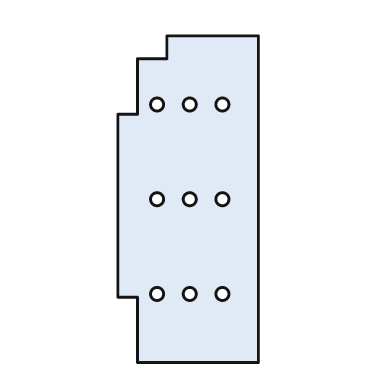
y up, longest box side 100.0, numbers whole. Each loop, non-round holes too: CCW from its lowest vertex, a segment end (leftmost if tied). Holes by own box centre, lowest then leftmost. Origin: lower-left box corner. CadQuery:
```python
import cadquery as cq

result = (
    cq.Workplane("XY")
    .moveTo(6.0, 0.0)
    .lineTo(43.0, 0.0)
    .lineTo(43.0, 100.0)
    .lineTo(15.0, 100.0)
    .lineTo(15.0, 93.0)
    .lineTo(6.0, 93.0)
    .lineTo(6.0, 76.0)
    .lineTo(0.0, 76.0)
    .lineTo(0.0, 20.0)
    .lineTo(6.0, 20.0)
    .close()
    .moveTo(12.0, 21.0)
    .circle(2.0)
    .moveTo(22.0, 21.0)
    .circle(2.0)
    .moveTo(32.0, 21.0)
    .circle(2.0)
    .moveTo(12.0, 50.0)
    .circle(2.0)
    .moveTo(22.0, 50.0)
    .circle(2.0)
    .moveTo(32.0, 50.0)
    .circle(2.0)
    .moveTo(12.0, 79.0)
    .circle(2.0)
    .moveTo(22.0, 79.0)
    .circle(2.0)
    .moveTo(32.0, 79.0)
    .circle(2.0)
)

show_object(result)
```